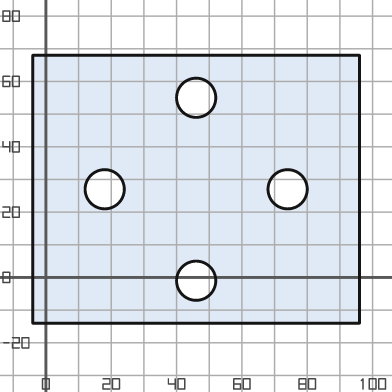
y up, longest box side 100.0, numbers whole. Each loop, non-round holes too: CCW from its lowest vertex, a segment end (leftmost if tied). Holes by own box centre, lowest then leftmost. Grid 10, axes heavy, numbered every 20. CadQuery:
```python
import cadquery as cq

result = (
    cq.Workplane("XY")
    .moveTo(-4.0, -14.0)
    .lineTo(96.0, -14.0)
    .lineTo(96.0, 68.0)
    .lineTo(-4.0, 68.0)
    .close()
    .moveTo(46.0, -1.0)
    .circle(6.0)
    .moveTo(18.0, 27.0)
    .circle(6.0)
    .moveTo(74.0, 27.0)
    .circle(6.0)
    .moveTo(46.0, 55.0)
    .circle(6.0)
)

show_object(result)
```